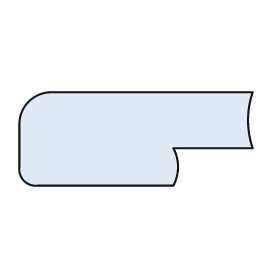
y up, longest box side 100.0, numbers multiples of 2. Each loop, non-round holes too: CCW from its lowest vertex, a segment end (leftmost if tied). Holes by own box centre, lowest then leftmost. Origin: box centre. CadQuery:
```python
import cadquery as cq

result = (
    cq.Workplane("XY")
    .moveTo(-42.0, -20.0)
    .lineTo(16.0, -20.0)
    .threePointArc((18.0, -12.0), (16.0, -4.0))
    .lineTo(50.0, -4.0)
    .threePointArc((48.0, 8.0), (50.0, 20.0))
    .lineTo(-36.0, 20.0)
    .threePointArc((-46.0, 16.0), (-50.0, 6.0))
    .lineTo(-50.0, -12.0)
    .threePointArc((-48.0, -18.0), (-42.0, -20.0))
    .close()
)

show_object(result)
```